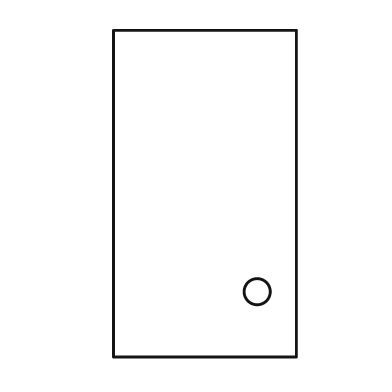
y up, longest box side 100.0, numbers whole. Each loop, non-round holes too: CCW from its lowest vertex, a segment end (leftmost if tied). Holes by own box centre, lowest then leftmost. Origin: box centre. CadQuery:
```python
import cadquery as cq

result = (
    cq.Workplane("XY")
    .moveTo(-28.0, -50.0)
    .lineTo(28.0, -50.0)
    .lineTo(28.0, 50.0)
    .lineTo(-28.0, 50.0)
    .close()
    .moveTo(16.0, -30.0)
    .circle(4.0)
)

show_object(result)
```